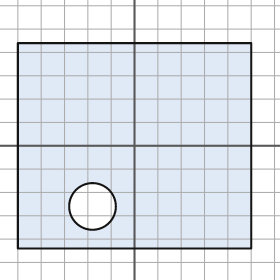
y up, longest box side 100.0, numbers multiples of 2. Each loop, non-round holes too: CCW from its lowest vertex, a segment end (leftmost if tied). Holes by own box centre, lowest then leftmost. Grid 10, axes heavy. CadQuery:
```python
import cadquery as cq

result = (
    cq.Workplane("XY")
    .moveTo(-50.0, -44.0)
    .lineTo(50.0, -44.0)
    .lineTo(50.0, 44.0)
    .lineTo(-50.0, 44.0)
    .close()
    .moveTo(-18.0, -26.0)
    .circle(10.0)
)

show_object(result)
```